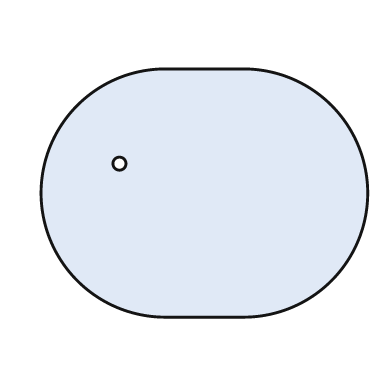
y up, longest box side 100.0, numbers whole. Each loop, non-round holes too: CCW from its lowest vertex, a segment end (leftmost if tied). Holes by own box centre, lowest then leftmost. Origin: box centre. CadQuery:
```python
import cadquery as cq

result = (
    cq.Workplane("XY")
    .moveTo(-12.0, -38.0)
    .lineTo(12.0, -38.0)
    .threePointArc((50.0, 0.0), (12.0, 38.0))
    .lineTo(-12.0, 38.0)
    .threePointArc((-50.0, 0.0), (-12.0, -38.0))
    .close()
    .moveTo(-26.0, 9.0)
    .circle(2.0)
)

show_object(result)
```